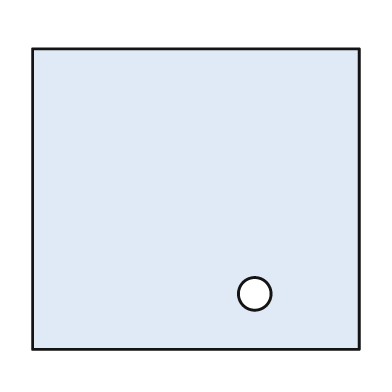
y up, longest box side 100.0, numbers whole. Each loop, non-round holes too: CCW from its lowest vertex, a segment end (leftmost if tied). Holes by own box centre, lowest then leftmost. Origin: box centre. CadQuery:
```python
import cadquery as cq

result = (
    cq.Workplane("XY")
    .moveTo(-50.0, -46.0)
    .lineTo(50.0, -46.0)
    .lineTo(50.0, 46.0)
    .lineTo(-50.0, 46.0)
    .close()
    .moveTo(18.0, -29.0)
    .circle(5.0)
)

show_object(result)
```